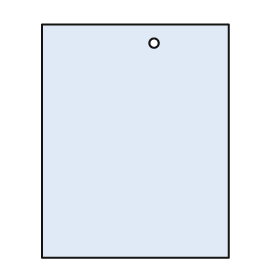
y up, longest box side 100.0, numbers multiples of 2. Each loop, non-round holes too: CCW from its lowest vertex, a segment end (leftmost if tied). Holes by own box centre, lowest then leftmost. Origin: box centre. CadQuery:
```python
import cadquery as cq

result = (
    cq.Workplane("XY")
    .moveTo(-40.0, -50.0)
    .lineTo(40.0, -50.0)
    .lineTo(40.0, 50.0)
    .lineTo(-40.0, 50.0)
    .close()
    .moveTo(8.0, 42.0)
    .circle(2.0)
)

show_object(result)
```